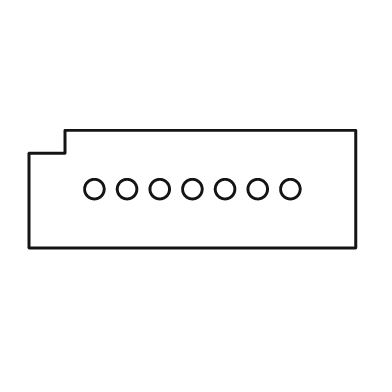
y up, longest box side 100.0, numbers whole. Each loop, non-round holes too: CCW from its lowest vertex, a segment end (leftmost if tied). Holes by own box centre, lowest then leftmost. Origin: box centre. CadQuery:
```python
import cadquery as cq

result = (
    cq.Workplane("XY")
    .moveTo(-50.0, -18.0)
    .lineTo(50.0, -18.0)
    .lineTo(50.0, 18.0)
    .lineTo(-39.0, 18.0)
    .lineTo(-39.0, 11.0)
    .lineTo(-50.0, 11.0)
    .close()
    .moveTo(-30.0, 0.0)
    .circle(3.0)
    .moveTo(-20.0, 0.0)
    .circle(3.0)
    .moveTo(-10.0, 0.0)
    .circle(3.0)
    .moveTo(0.0, 0.0)
    .circle(3.0)
    .moveTo(10.0, 0.0)
    .circle(3.0)
    .moveTo(20.0, 0.0)
    .circle(3.0)
    .moveTo(30.0, 0.0)
    .circle(3.0)
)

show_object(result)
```